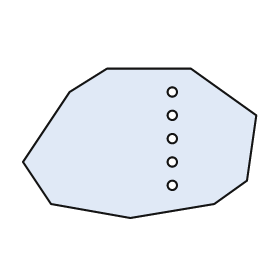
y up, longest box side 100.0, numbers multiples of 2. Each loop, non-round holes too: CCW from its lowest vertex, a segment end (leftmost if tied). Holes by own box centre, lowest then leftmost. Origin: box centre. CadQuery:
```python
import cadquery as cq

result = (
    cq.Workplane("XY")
    .moveTo(-4.0, -32.0)
    .lineTo(32.0, -26.0)
    .lineTo(46.0, -16.0)
    .lineTo(50.0, 12.0)
    .lineTo(22.0, 32.0)
    .lineTo(-14.0, 32.0)
    .lineTo(-30.0, 22.0)
    .lineTo(-50.0, -8.0)
    .lineTo(-38.0, -26.0)
    .close()
    .moveTo(14.0, -18.0)
    .circle(2.0)
    .moveTo(14.0, -8.0)
    .circle(2.0)
    .moveTo(14.0, 2.0)
    .circle(2.0)
    .moveTo(14.0, 12.0)
    .circle(2.0)
    .moveTo(14.0, 22.0)
    .circle(2.0)
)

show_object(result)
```